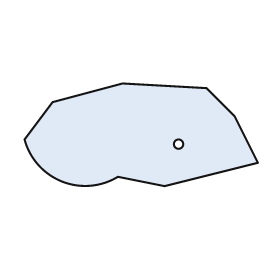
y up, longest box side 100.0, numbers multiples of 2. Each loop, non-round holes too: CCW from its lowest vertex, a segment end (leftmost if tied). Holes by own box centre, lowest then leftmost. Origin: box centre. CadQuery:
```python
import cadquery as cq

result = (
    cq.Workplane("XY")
    .moveTo(10.0, -22.0)
    .lineTo(50.0, -12.0)
    .lineTo(40.0, 8.0)
    .lineTo(28.0, 20.0)
    .lineTo(-8.0, 22.0)
    .lineTo(-38.0, 14.0)
    .lineTo(-50.0, -2.0)
    .threePointArc((-34.0, -20.0), (-10.0, -18.0))
    .close()
    .moveTo(16.0, -4.0)
    .circle(2.0)
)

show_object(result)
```